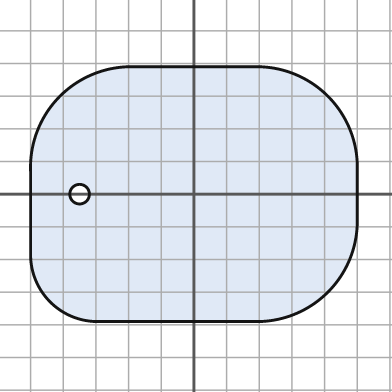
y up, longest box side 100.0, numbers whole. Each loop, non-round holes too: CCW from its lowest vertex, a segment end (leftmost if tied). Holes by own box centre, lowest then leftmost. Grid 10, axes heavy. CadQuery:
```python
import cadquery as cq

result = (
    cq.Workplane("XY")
    .moveTo(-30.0, -39.0)
    .lineTo(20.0, -39.0)
    .threePointArc((41.0, -30.0), (50.0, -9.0))
    .lineTo(50.0, 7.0)
    .threePointArc((41.0, 30.0), (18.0, 39.0))
    .lineTo(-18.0, 39.0)
    .threePointArc((-41.0, 30.0), (-50.0, 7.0))
    .lineTo(-50.0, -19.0)
    .threePointArc((-44.0, -33.0), (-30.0, -39.0))
    .close()
    .moveTo(-35.0, 0.0)
    .circle(3.0)
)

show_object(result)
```